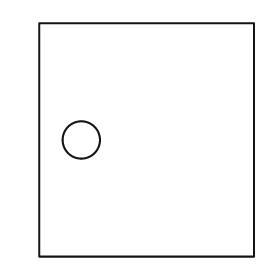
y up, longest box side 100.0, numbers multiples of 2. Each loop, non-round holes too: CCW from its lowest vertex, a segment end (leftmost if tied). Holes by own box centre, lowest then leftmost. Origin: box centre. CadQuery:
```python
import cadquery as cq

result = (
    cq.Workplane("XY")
    .moveTo(-46.0, -50.0)
    .lineTo(46.0, -50.0)
    .lineTo(46.0, 50.0)
    .lineTo(-46.0, 50.0)
    .close()
    .moveTo(-28.0, 0.0)
    .circle(8.0)
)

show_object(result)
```